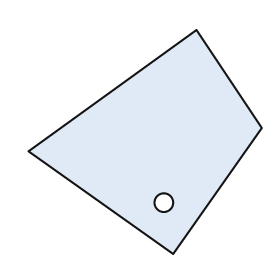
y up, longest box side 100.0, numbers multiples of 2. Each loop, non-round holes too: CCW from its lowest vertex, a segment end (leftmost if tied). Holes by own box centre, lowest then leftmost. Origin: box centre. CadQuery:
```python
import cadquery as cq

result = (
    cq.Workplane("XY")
    .moveTo(12.0, -48.0)
    .lineTo(50.0, 6.0)
    .lineTo(22.0, 48.0)
    .lineTo(-50.0, -4.0)
    .close()
    .moveTo(8.0, -26.0)
    .circle(4.0)
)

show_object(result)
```